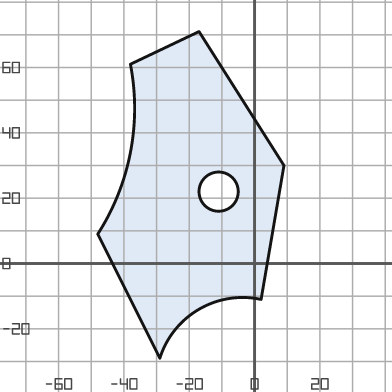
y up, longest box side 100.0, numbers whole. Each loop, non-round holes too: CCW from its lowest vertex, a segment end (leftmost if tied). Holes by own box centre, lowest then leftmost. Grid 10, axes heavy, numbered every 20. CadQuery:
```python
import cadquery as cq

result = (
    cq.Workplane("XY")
    .moveTo(-29.0, -29.0)
    .threePointArc((-17.0, -14.0), (2.0, -11.0))
    .lineTo(9.0, 30.0)
    .lineTo(-17.0, 71.0)
    .lineTo(-38.0, 61.0)
    .threePointArc((-38.0, 34.0), (-48.0, 9.0))
    .close()
    .moveTo(-11.0, 22.0)
    .circle(6.0)
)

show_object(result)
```